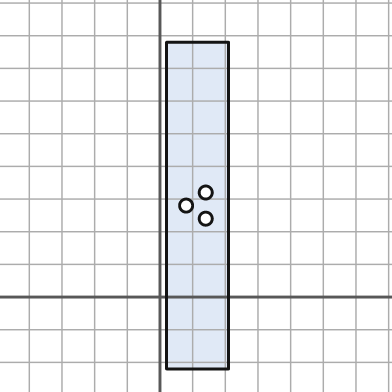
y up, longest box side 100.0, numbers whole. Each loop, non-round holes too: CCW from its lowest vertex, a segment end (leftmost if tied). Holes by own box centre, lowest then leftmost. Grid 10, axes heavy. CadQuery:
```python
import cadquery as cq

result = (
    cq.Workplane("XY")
    .moveTo(2.0, -22.0)
    .lineTo(21.0, -22.0)
    .lineTo(21.0, 78.0)
    .lineTo(2.0, 78.0)
    .close()
    .moveTo(14.0, 24.0)
    .circle(2.0)
    .moveTo(8.0, 28.0)
    .circle(2.0)
    .moveTo(14.0, 32.0)
    .circle(2.0)
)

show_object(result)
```